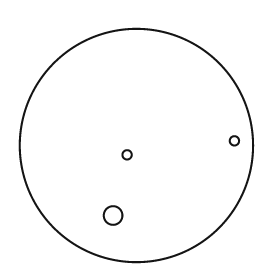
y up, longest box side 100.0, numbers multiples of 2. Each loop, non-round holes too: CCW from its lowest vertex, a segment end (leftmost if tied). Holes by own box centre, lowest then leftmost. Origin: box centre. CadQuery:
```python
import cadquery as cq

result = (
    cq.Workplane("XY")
    .moveTo(0.0, 0.0)
    .circle(50.0)
    .moveTo(-10.0, -30.0)
    .circle(4.0)
    .moveTo(-4.0, -4.0)
    .circle(2.0)
    .moveTo(42.0, 2.0)
    .circle(2.0)
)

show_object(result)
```